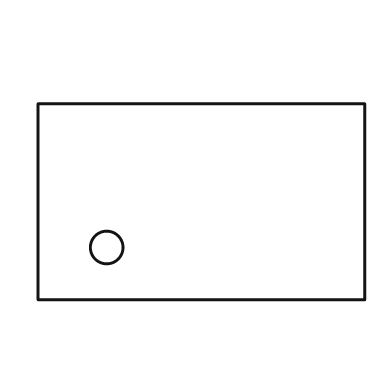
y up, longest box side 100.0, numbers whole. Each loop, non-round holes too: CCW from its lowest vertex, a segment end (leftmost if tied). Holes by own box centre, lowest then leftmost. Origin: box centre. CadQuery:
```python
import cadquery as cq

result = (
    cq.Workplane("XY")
    .moveTo(-50.0, -30.0)
    .lineTo(50.0, -30.0)
    .lineTo(50.0, 30.0)
    .lineTo(-50.0, 30.0)
    .close()
    .moveTo(-29.0, -14.0)
    .circle(5.0)
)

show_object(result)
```